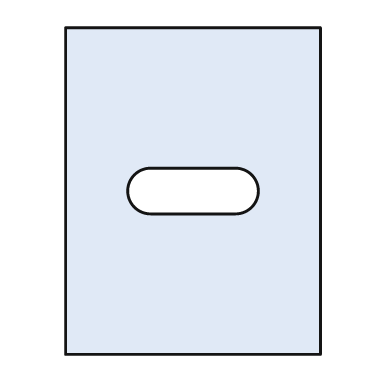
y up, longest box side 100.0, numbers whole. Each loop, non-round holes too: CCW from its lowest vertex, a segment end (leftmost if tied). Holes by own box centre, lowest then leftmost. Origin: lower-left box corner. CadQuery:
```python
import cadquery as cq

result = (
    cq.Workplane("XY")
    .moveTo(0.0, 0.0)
    .lineTo(78.0, 0.0)
    .lineTo(78.0, 100.0)
    .lineTo(0.0, 100.0)
    .close()
    .moveTo(26.0, 43.0)
    .lineTo(52.0, 43.0)
    .threePointArc((59.0, 50.0), (52.0, 57.0))
    .lineTo(26.0, 57.0)
    .threePointArc((19.0, 50.0), (26.0, 43.0))
    .close()
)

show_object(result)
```